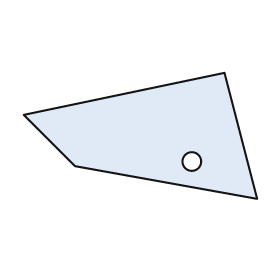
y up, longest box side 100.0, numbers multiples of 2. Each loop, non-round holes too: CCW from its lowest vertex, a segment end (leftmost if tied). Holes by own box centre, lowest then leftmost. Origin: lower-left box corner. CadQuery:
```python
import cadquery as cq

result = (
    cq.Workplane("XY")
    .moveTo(100.0, 0.0)
    .lineTo(86.0, 54.0)
    .lineTo(0.0, 36.0)
    .lineTo(22.0, 14.0)
    .close()
    .moveTo(72.0, 16.0)
    .circle(4.0)
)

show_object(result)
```